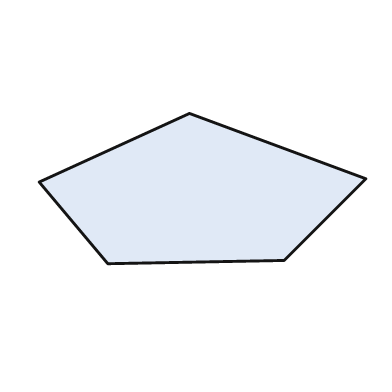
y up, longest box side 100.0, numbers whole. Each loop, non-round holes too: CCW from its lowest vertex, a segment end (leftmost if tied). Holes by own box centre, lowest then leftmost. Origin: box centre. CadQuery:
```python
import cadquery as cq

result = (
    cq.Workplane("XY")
    .moveTo(-29.0, -23.0)
    .lineTo(25.0, -22.0)
    .lineTo(50.0, 3.0)
    .lineTo(-4.0, 23.0)
    .lineTo(-50.0, 2.0)
    .close()
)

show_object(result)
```